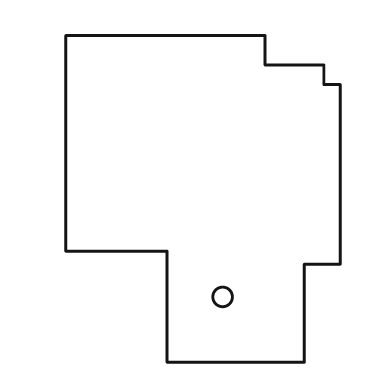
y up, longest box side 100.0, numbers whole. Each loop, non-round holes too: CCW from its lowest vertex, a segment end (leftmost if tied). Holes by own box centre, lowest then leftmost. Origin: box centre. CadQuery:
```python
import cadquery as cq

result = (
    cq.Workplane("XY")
    .moveTo(-11.0, -50.0)
    .lineTo(31.0, -50.0)
    .lineTo(31.0, -20.0)
    .lineTo(42.0, -20.0)
    .lineTo(42.0, 35.0)
    .lineTo(37.0, 35.0)
    .lineTo(37.0, 41.0)
    .lineTo(19.0, 41.0)
    .lineTo(19.0, 50.0)
    .lineTo(-42.0, 50.0)
    .lineTo(-42.0, -16.0)
    .lineTo(-11.0, -16.0)
    .close()
    .moveTo(6.0, -30.0)
    .circle(3.0)
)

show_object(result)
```